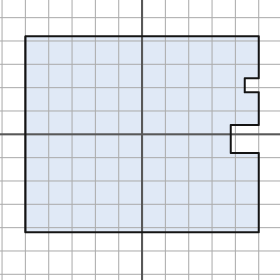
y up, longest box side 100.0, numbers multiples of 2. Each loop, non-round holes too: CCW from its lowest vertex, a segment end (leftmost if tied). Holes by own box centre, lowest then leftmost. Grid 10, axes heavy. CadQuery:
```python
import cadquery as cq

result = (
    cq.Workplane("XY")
    .moveTo(-50.0, -42.0)
    .lineTo(50.0, -42.0)
    .lineTo(50.0, -8.0)
    .lineTo(38.0, -8.0)
    .lineTo(38.0, 4.0)
    .lineTo(50.0, 4.0)
    .lineTo(50.0, 18.0)
    .lineTo(44.0, 18.0)
    .lineTo(44.0, 24.0)
    .lineTo(50.0, 24.0)
    .lineTo(50.0, 42.0)
    .lineTo(-50.0, 42.0)
    .close()
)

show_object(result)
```